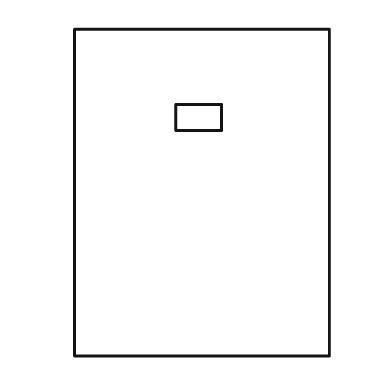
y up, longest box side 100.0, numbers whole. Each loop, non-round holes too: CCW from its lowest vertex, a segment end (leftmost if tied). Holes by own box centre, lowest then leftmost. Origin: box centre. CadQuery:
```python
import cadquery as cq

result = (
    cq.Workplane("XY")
    .moveTo(-39.0, -50.0)
    .lineTo(39.0, -50.0)
    .lineTo(39.0, 50.0)
    .lineTo(-39.0, 50.0)
    .close()
    .moveTo(-8.0, 19.0)
    .lineTo(6.0, 19.0)
    .lineTo(6.0, 27.0)
    .lineTo(-8.0, 27.0)
    .close()
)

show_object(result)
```